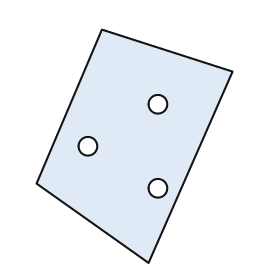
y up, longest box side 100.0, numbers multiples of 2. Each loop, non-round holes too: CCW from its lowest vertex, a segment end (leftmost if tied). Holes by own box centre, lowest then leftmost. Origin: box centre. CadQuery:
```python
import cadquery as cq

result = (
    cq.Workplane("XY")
    .moveTo(6.0, -50.0)
    .lineTo(42.0, 32.0)
    .lineTo(-14.0, 50.0)
    .lineTo(-42.0, -16.0)
    .close()
    .moveTo(10.0, -18.0)
    .circle(4.0)
    .moveTo(-20.0, 0.0)
    .circle(4.0)
    .moveTo(10.0, 18.0)
    .circle(4.0)
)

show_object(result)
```